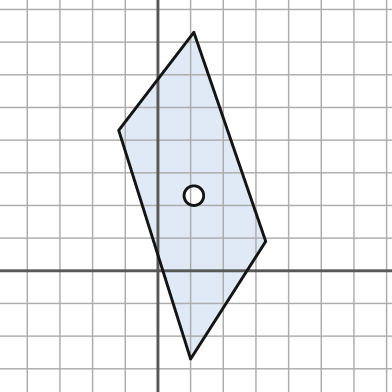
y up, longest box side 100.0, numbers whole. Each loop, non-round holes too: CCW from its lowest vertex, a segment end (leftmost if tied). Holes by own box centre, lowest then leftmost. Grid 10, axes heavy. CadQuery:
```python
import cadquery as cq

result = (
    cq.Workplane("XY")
    .moveTo(10.0, -27.0)
    .lineTo(33.0, 9.0)
    .lineTo(11.0, 73.0)
    .lineTo(-12.0, 43.0)
    .close()
    .moveTo(11.0, 23.0)
    .circle(3.0)
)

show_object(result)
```